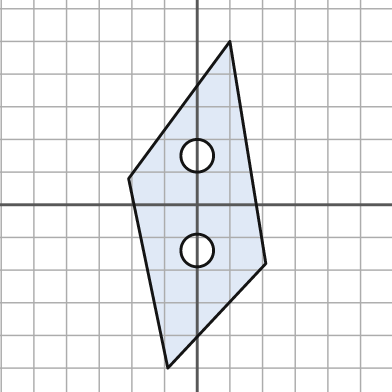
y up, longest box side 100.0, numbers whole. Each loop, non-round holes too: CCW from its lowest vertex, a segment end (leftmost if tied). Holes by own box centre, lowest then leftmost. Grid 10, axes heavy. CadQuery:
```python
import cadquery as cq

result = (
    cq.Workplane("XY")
    .moveTo(-9.0, -50.0)
    .lineTo(21.0, -18.0)
    .lineTo(10.0, 50.0)
    .lineTo(-21.0, 8.0)
    .close()
    .moveTo(0.0, -14.0)
    .circle(5.0)
    .moveTo(0.0, 15.0)
    .circle(5.0)
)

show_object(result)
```